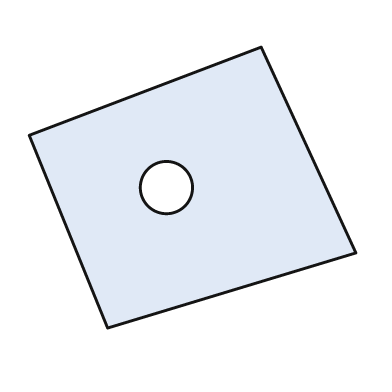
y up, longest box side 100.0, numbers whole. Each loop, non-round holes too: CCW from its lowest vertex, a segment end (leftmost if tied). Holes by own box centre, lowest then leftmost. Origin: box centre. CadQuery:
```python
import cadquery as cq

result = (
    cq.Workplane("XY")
    .moveTo(-26.0, -43.0)
    .lineTo(50.0, -20.0)
    .lineTo(21.0, 43.0)
    .lineTo(-50.0, 16.0)
    .close()
    .moveTo(-8.0, 0.0)
    .circle(8.0)
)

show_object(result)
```